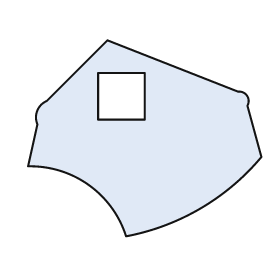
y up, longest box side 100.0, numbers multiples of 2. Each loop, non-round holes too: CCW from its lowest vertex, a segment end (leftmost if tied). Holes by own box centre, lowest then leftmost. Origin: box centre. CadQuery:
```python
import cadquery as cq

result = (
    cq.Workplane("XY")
    .moveTo(-8.0, -42.0)
    .threePointArc((24.0, -30.0), (50.0, -8.0))
    .lineTo(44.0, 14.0)
    .threePointArc((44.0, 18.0), (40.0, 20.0))
    .lineTo(-16.0, 42.0)
    .lineTo(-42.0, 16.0)
    .threePointArc((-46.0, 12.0), (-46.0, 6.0))
    .lineTo(-50.0, -12.0)
    .threePointArc((-24.0, -20.0), (-8.0, -42.0))
    .close()
    .moveTo(-20.0, 8.0)
    .lineTo(0.0, 8.0)
    .lineTo(0.0, 28.0)
    .lineTo(-20.0, 28.0)
    .close()
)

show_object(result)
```